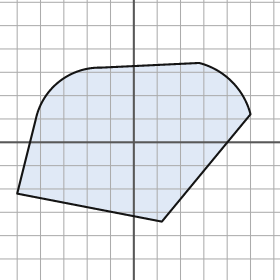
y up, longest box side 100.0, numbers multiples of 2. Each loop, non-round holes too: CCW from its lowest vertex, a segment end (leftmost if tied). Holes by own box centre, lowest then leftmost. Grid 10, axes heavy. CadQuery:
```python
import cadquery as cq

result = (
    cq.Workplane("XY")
    .moveTo(12.0, -34.0)
    .lineTo(50.0, 12.0)
    .threePointArc((42.0, 26.0), (28.0, 34.0))
    .lineTo(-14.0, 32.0)
    .threePointArc((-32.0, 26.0), (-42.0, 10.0))
    .lineTo(-50.0, -22.0)
    .close()
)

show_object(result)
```